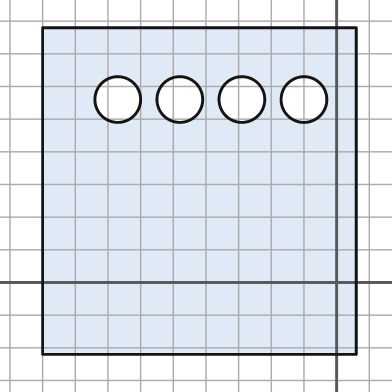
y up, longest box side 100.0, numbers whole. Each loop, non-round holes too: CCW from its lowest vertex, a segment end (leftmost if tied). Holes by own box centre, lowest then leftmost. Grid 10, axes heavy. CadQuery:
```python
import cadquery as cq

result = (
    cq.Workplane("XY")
    .moveTo(-90.0, -22.0)
    .lineTo(6.0, -22.0)
    .lineTo(6.0, 78.0)
    .lineTo(-90.0, 78.0)
    .close()
    .moveTo(-67.0, 56.0)
    .circle(7.0)
    .moveTo(-48.0, 56.0)
    .circle(7.0)
    .moveTo(-29.0, 56.0)
    .circle(7.0)
    .moveTo(-10.0, 56.0)
    .circle(7.0)
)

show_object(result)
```